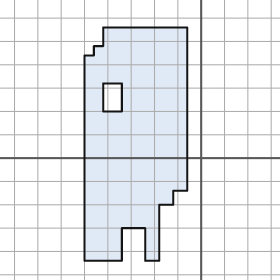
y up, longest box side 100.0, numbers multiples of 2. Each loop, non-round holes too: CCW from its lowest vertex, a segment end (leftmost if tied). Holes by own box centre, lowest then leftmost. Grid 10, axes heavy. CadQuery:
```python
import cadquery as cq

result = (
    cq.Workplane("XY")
    .moveTo(-50.0, -44.0)
    .lineTo(-34.0, -44.0)
    .lineTo(-34.0, -30.0)
    .lineTo(-24.0, -30.0)
    .lineTo(-24.0, -44.0)
    .lineTo(-18.0, -44.0)
    .lineTo(-18.0, -20.0)
    .lineTo(-12.0, -20.0)
    .lineTo(-12.0, -14.0)
    .lineTo(-6.0, -14.0)
    .lineTo(-6.0, 56.0)
    .lineTo(-42.0, 56.0)
    .lineTo(-42.0, 48.0)
    .lineTo(-46.0, 48.0)
    .lineTo(-46.0, 44.0)
    .lineTo(-50.0, 44.0)
    .close()
    .moveTo(-42.0, 20.0)
    .lineTo(-34.0, 20.0)
    .lineTo(-34.0, 32.0)
    .lineTo(-42.0, 32.0)
    .close()
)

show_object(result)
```